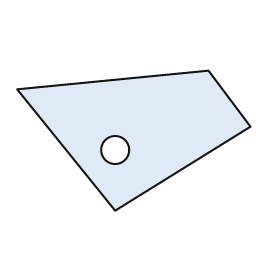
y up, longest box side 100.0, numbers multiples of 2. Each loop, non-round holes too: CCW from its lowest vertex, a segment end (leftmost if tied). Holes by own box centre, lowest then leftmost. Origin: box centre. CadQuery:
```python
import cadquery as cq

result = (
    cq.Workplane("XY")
    .moveTo(-8.0, -30.0)
    .lineTo(50.0, 6.0)
    .lineTo(32.0, 30.0)
    .lineTo(-50.0, 22.0)
    .close()
    .moveTo(-8.0, -4.0)
    .circle(6.0)
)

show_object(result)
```